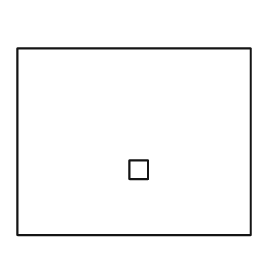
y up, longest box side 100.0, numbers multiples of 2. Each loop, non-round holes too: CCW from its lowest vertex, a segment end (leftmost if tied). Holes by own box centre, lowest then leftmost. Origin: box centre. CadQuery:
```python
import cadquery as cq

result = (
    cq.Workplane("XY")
    .moveTo(-50.0, -40.0)
    .lineTo(50.0, -40.0)
    .lineTo(50.0, 40.0)
    .lineTo(-50.0, 40.0)
    .close()
    .moveTo(-2.0, -16.0)
    .lineTo(6.0, -16.0)
    .lineTo(6.0, -8.0)
    .lineTo(-2.0, -8.0)
    .close()
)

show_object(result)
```